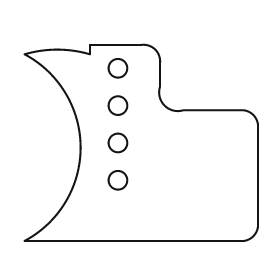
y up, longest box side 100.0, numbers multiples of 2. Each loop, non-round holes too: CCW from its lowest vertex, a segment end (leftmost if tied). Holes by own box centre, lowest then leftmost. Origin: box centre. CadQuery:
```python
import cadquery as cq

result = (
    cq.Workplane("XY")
    .moveTo(-50.0, -42.0)
    .lineTo(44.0, -42.0)
    .threePointArc((48.0, -40.0), (50.0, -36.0))
    .lineTo(50.0, 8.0)
    .threePointArc((48.0, 12.0), (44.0, 14.0))
    .lineTo(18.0, 14.0)
    .threePointArc((10.0, 16.0), (8.0, 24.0))
    .lineTo(8.0, 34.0)
    .threePointArc((6.0, 40.0), (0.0, 42.0))
    .lineTo(-22.0, 42.0)
    .lineTo(-22.0, 38.0)
    .threePointArc((-36.0, 40.0), (-50.0, 38.0))
    .threePointArc((-26.0, -2.0), (-50.0, -42.0))
    .close()
    .moveTo(-10.0, -16.0)
    .circle(4.0)
    .moveTo(-10.0, 0.0)
    .circle(4.0)
    .moveTo(-10.0, 16.0)
    .circle(4.0)
    .moveTo(-10.0, 32.0)
    .circle(4.0)
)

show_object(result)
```